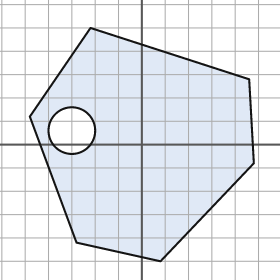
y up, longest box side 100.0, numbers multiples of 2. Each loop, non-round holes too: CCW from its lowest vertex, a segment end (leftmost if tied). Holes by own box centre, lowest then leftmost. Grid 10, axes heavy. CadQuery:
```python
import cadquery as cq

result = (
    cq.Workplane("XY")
    .moveTo(8.0, -50.0)
    .lineTo(48.0, -8.0)
    .lineTo(46.0, 28.0)
    .lineTo(-22.0, 50.0)
    .lineTo(-48.0, 12.0)
    .lineTo(-28.0, -42.0)
    .close()
    .moveTo(-30.0, 6.0)
    .circle(10.0)
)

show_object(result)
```